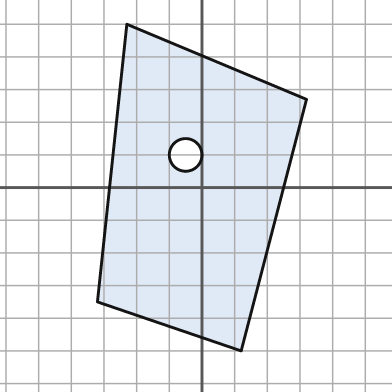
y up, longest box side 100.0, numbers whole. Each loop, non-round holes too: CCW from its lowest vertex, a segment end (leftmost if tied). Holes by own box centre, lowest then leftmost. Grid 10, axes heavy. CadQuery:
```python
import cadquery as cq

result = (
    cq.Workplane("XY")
    .moveTo(12.0, -50.0)
    .lineTo(32.0, 27.0)
    .lineTo(-23.0, 50.0)
    .lineTo(-32.0, -35.0)
    .close()
    .moveTo(-5.0, 10.0)
    .circle(5.0)
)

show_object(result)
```